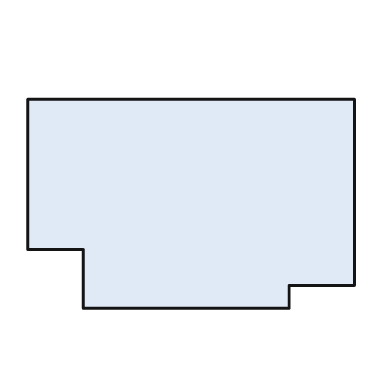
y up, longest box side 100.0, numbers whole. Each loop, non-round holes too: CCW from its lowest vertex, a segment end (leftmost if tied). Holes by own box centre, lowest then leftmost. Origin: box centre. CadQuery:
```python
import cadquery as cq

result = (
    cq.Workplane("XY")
    .moveTo(-33.0, -32.0)
    .lineTo(30.0, -32.0)
    .lineTo(30.0, -25.0)
    .lineTo(50.0, -25.0)
    .lineTo(50.0, 32.0)
    .lineTo(-50.0, 32.0)
    .lineTo(-50.0, -14.0)
    .lineTo(-33.0, -14.0)
    .close()
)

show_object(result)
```